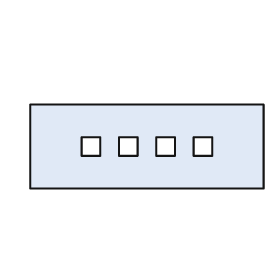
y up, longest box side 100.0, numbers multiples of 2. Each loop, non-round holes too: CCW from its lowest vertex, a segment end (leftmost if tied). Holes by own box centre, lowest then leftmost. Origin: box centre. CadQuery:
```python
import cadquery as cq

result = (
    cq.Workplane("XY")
    .moveTo(-50.0, -18.0)
    .lineTo(50.0, -18.0)
    .lineTo(50.0, 18.0)
    .lineTo(-50.0, 18.0)
    .close()
    .moveTo(-28.0, -4.0)
    .lineTo(-20.0, -4.0)
    .lineTo(-20.0, 4.0)
    .lineTo(-28.0, 4.0)
    .close()
    .moveTo(-12.0, -4.0)
    .lineTo(-4.0, -4.0)
    .lineTo(-4.0, 4.0)
    .lineTo(-12.0, 4.0)
    .close()
    .moveTo(4.0, -4.0)
    .lineTo(12.0, -4.0)
    .lineTo(12.0, 4.0)
    .lineTo(4.0, 4.0)
    .close()
    .moveTo(20.0, -4.0)
    .lineTo(28.0, -4.0)
    .lineTo(28.0, 4.0)
    .lineTo(20.0, 4.0)
    .close()
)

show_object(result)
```